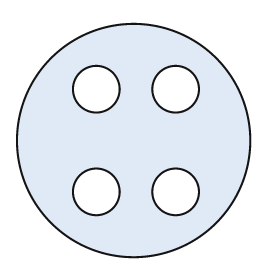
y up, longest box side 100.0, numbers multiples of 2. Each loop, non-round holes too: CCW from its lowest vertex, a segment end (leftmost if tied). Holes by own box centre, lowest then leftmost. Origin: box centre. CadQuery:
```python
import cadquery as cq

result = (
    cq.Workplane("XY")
    .moveTo(0.0, 0.0)
    .circle(50.0)
    .moveTo(-16.0, -22.0)
    .circle(10.0)
    .moveTo(18.0, -22.0)
    .circle(10.0)
    .moveTo(-16.0, 22.0)
    .circle(10.0)
    .moveTo(18.0, 22.0)
    .circle(10.0)
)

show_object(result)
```